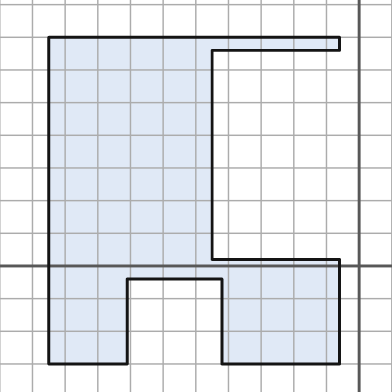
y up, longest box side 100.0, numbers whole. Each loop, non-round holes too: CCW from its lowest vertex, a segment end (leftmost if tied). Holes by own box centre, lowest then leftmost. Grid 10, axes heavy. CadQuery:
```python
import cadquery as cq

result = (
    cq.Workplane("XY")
    .moveTo(-95.0, -30.0)
    .lineTo(-71.0, -30.0)
    .lineTo(-71.0, -4.0)
    .lineTo(-42.0, -4.0)
    .lineTo(-42.0, -30.0)
    .lineTo(-6.0, -30.0)
    .lineTo(-6.0, 2.0)
    .lineTo(-45.0, 2.0)
    .lineTo(-45.0, 66.0)
    .lineTo(-6.0, 66.0)
    .lineTo(-6.0, 70.0)
    .lineTo(-95.0, 70.0)
    .close()
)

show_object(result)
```